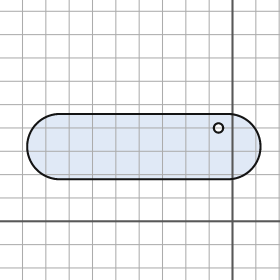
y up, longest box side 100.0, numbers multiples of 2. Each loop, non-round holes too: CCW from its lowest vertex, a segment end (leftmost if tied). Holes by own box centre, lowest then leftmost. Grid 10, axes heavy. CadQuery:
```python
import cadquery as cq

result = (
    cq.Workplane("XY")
    .moveTo(-74.0, 18.0)
    .lineTo(-2.0, 18.0)
    .threePointArc((12.0, 32.0), (-2.0, 46.0))
    .lineTo(-74.0, 46.0)
    .threePointArc((-88.0, 32.0), (-74.0, 18.0))
    .close()
    .moveTo(-6.0, 40.0)
    .circle(2.0)
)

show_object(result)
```